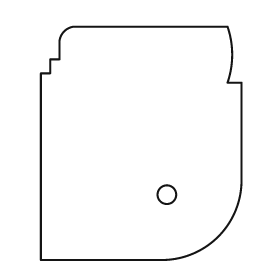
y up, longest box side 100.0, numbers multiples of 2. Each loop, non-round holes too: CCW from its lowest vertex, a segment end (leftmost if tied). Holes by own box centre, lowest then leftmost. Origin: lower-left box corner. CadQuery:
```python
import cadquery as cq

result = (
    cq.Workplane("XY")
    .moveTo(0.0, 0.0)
    .lineTo(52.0, 0.0)
    .threePointArc((76.0, 10.0), (86.0, 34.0))
    .lineTo(86.0, 76.0)
    .lineTo(80.0, 76.0)
    .threePointArc((82.0, 88.0), (80.0, 100.0))
    .lineTo(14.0, 100.0)
    .threePointArc((10.0, 98.0), (8.0, 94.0))
    .lineTo(8.0, 86.0)
    .lineTo(4.0, 86.0)
    .lineTo(4.0, 80.0)
    .lineTo(0.0, 80.0)
    .close()
    .moveTo(54.0, 28.0)
    .circle(4.0)
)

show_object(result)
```